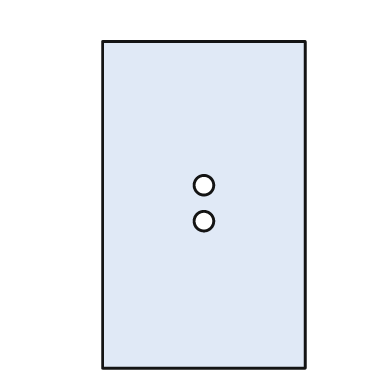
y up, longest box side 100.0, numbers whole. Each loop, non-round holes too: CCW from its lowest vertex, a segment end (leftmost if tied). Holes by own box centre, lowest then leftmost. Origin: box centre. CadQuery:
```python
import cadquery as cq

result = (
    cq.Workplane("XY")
    .moveTo(-31.0, -50.0)
    .lineTo(31.0, -50.0)
    .lineTo(31.0, 50.0)
    .lineTo(-31.0, 50.0)
    .close()
    .moveTo(0.0, -5.0)
    .circle(3.0)
    .moveTo(0.0, 6.0)
    .circle(3.0)
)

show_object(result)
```